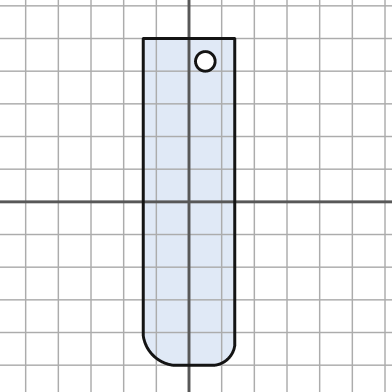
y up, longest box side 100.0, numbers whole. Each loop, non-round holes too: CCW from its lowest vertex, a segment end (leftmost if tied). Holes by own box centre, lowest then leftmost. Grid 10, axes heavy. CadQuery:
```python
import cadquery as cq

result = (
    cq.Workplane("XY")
    .moveTo(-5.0, -50.0)
    .lineTo(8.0, -50.0)
    .threePointArc((12.0, -48.0), (14.0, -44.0))
    .lineTo(14.0, 50.0)
    .lineTo(-14.0, 50.0)
    .lineTo(-14.0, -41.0)
    .threePointArc((-11.0, -47.0), (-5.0, -50.0))
    .close()
    .moveTo(5.0, 43.0)
    .circle(3.0)
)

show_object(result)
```